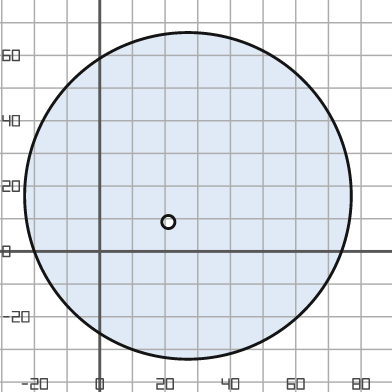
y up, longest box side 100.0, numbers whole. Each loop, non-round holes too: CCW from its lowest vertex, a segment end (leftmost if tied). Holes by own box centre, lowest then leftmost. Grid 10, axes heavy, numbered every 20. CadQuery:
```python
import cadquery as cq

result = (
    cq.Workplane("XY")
    .moveTo(27.0, 17.0)
    .circle(50.0)
    .moveTo(21.0, 9.0)
    .circle(2.0)
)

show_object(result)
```